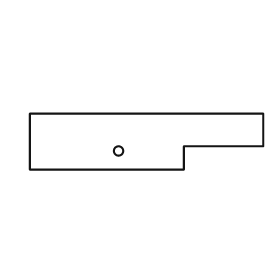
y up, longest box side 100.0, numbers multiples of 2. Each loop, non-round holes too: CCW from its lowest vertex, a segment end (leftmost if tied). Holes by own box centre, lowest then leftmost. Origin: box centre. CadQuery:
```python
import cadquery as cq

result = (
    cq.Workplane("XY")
    .moveTo(-50.0, -12.0)
    .lineTo(16.0, -12.0)
    .lineTo(16.0, -2.0)
    .lineTo(50.0, -2.0)
    .lineTo(50.0, 12.0)
    .lineTo(-50.0, 12.0)
    .close()
    .moveTo(-12.0, -4.0)
    .circle(2.0)
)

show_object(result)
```